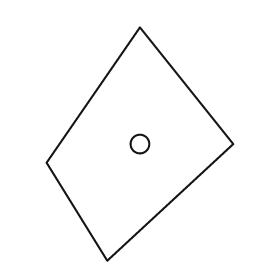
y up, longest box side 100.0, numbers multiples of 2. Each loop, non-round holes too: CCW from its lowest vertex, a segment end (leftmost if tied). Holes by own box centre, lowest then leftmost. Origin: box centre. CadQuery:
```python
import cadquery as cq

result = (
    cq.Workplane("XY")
    .moveTo(-14.0, -50.0)
    .lineTo(40.0, 0.0)
    .lineTo(0.0, 50.0)
    .lineTo(-40.0, -8.0)
    .close()
    .moveTo(0.0, 0.0)
    .circle(4.0)
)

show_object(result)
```